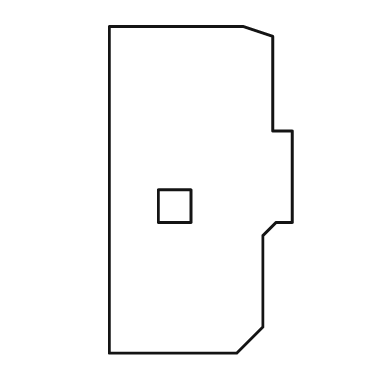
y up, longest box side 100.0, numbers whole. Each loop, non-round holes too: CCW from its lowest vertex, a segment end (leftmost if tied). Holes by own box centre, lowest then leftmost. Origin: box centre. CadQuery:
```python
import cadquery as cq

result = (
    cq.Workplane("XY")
    .moveTo(-28.0, -50.0)
    .lineTo(11.0, -50.0)
    .lineTo(19.0, -42.0)
    .lineTo(19.0, -14.0)
    .lineTo(23.0, -10.0)
    .lineTo(28.0, -10.0)
    .lineTo(28.0, 18.0)
    .lineTo(22.0, 18.0)
    .lineTo(22.0, 47.0)
    .lineTo(13.0, 50.0)
    .lineTo(-28.0, 50.0)
    .close()
    .moveTo(-13.0, -10.0)
    .lineTo(-3.0, -10.0)
    .lineTo(-3.0, 0.0)
    .lineTo(-13.0, 0.0)
    .close()
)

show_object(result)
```